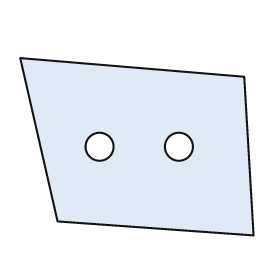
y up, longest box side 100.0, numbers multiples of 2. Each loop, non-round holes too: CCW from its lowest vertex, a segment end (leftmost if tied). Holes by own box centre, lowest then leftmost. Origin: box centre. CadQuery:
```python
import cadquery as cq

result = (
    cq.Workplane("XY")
    .moveTo(50.0, -38.0)
    .lineTo(46.0, 30.0)
    .lineTo(-50.0, 38.0)
    .lineTo(-34.0, -32.0)
    .close()
    .moveTo(-16.0, 0.0)
    .circle(6.0)
    .moveTo(18.0, 0.0)
    .circle(6.0)
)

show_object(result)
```